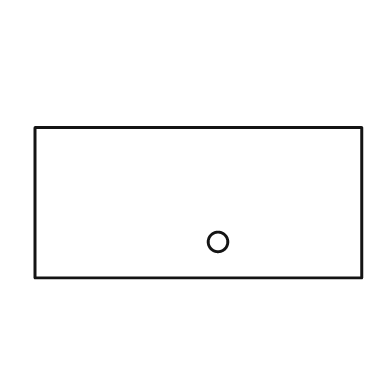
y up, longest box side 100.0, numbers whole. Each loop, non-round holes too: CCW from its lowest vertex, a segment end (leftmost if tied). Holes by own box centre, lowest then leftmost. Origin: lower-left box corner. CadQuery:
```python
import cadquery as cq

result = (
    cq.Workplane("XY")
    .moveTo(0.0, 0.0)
    .lineTo(100.0, 0.0)
    .lineTo(100.0, 46.0)
    .lineTo(0.0, 46.0)
    .close()
    .moveTo(56.0, 11.0)
    .circle(3.0)
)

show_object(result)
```